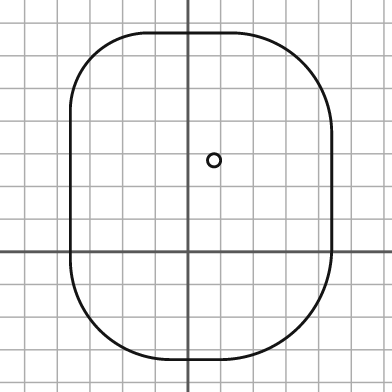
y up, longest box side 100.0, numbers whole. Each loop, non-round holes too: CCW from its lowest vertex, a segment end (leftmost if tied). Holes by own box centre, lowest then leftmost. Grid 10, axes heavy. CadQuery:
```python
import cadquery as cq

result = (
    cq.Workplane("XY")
    .moveTo(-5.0, -33.0)
    .lineTo(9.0, -33.0)
    .threePointArc((34.0, -23.0), (44.0, 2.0))
    .lineTo(44.0, 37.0)
    .threePointArc((35.0, 58.0), (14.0, 67.0))
    .lineTo(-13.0, 67.0)
    .threePointArc((-29.0, 60.0), (-36.0, 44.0))
    .lineTo(-36.0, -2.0)
    .threePointArc((-27.0, -24.0), (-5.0, -33.0))
    .close()
    .moveTo(8.0, 28.0)
    .circle(2.0)
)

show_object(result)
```